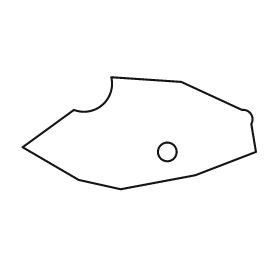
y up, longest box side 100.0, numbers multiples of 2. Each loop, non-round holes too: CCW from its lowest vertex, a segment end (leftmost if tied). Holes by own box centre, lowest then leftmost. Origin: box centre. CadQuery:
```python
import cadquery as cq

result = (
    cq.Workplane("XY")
    .moveTo(-8.0, -24.0)
    .lineTo(24.0, -18.0)
    .lineTo(50.0, -8.0)
    .lineTo(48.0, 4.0)
    .threePointArc((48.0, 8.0), (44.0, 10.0))
    .lineTo(18.0, 22.0)
    .lineTo(-12.0, 24.0)
    .threePointArc((-16.0, 12.0), (-28.0, 10.0))
    .lineTo(-50.0, -6.0)
    .lineTo(-26.0, -20.0)
    .close()
    .moveTo(12.0, -8.0)
    .circle(4.0)
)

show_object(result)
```